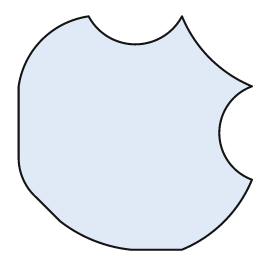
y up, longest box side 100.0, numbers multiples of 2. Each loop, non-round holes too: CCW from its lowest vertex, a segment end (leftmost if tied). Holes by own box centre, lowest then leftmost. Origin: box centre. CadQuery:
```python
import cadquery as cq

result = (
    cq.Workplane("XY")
    .moveTo(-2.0, -50.0)
    .lineTo(20.0, -50.0)
    .threePointArc((38.0, -38.0), (50.0, -20.0))
    .threePointArc((36.0, 0.0), (50.0, 20.0))
    .threePointArc((32.0, 32.0), (20.0, 50.0))
    .threePointArc((0.0, 38.0), (-20.0, 50.0))
    .threePointArc((-40.0, 40.0), (-50.0, 20.0))
    .lineTo(-50.0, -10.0)
    .threePointArc((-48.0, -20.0), (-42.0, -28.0))
    .lineTo(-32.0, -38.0)
    .threePointArc((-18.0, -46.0), (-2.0, -50.0))
    .close()
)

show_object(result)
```